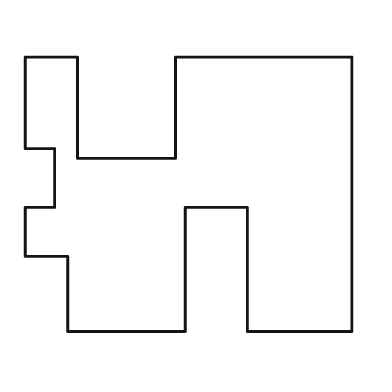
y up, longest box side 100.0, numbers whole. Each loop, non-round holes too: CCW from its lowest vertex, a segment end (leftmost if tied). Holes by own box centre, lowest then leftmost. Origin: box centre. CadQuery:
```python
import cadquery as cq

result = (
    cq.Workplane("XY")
    .moveTo(-37.0, -42.0)
    .lineTo(-1.0, -42.0)
    .lineTo(-1.0, -4.0)
    .lineTo(18.0, -4.0)
    .lineTo(18.0, -42.0)
    .lineTo(50.0, -42.0)
    .lineTo(50.0, 42.0)
    .lineTo(-4.0, 42.0)
    .lineTo(-4.0, 11.0)
    .lineTo(-34.0, 11.0)
    .lineTo(-34.0, 42.0)
    .lineTo(-50.0, 42.0)
    .lineTo(-50.0, 14.0)
    .lineTo(-41.0, 14.0)
    .lineTo(-41.0, -4.0)
    .lineTo(-50.0, -4.0)
    .lineTo(-50.0, -19.0)
    .lineTo(-37.0, -19.0)
    .close()
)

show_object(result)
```